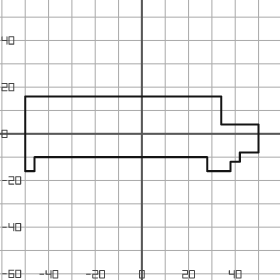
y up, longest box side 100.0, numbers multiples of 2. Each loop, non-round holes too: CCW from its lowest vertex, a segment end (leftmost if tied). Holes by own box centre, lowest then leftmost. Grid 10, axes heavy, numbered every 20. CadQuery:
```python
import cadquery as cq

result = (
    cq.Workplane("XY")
    .moveTo(-50.0, -16.0)
    .lineTo(-46.0, -16.0)
    .lineTo(-46.0, -10.0)
    .lineTo(28.0, -10.0)
    .lineTo(28.0, -16.0)
    .lineTo(38.0, -16.0)
    .lineTo(38.0, -12.0)
    .lineTo(42.0, -12.0)
    .lineTo(42.0, -8.0)
    .lineTo(50.0, -8.0)
    .lineTo(50.0, 4.0)
    .lineTo(34.0, 4.0)
    .lineTo(34.0, 16.0)
    .lineTo(-50.0, 16.0)
    .close()
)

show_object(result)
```